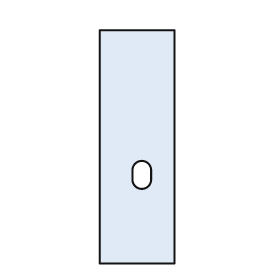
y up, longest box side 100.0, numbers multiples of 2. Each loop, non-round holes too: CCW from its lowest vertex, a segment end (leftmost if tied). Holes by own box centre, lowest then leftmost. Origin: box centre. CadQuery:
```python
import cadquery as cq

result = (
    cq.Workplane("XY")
    .moveTo(-16.0, -50.0)
    .lineTo(16.0, -50.0)
    .lineTo(16.0, 50.0)
    .lineTo(-16.0, 50.0)
    .close()
    .moveTo(-2.0, -14.0)
    .threePointArc((2.0, -18.0), (6.0, -14.0))
    .lineTo(6.0, -10.0)
    .threePointArc((2.0, -6.0), (-2.0, -10.0))
    .close()
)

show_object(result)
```